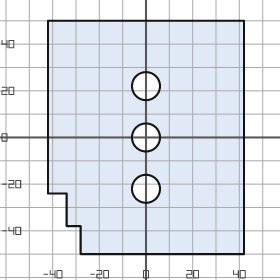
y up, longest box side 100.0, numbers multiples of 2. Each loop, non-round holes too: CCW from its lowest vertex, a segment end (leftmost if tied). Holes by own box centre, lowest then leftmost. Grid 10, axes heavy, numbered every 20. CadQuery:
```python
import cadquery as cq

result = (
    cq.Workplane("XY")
    .moveTo(-28.0, -50.0)
    .lineTo(42.0, -50.0)
    .lineTo(42.0, 50.0)
    .lineTo(-42.0, 50.0)
    .lineTo(-42.0, -24.0)
    .lineTo(-34.0, -24.0)
    .lineTo(-34.0, -38.0)
    .lineTo(-28.0, -38.0)
    .close()
    .moveTo(0.0, -22.0)
    .circle(6.0)
    .moveTo(0.0, 0.0)
    .circle(6.0)
    .moveTo(0.0, 22.0)
    .circle(6.0)
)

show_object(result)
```